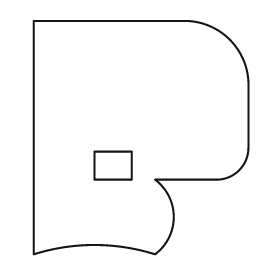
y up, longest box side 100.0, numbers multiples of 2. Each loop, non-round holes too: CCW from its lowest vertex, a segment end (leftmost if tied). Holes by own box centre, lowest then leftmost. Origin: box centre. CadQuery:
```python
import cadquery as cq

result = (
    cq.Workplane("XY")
    .moveTo(-46.0, -50.0)
    .threePointArc((-20.0, -46.0), (6.0, -50.0))
    .threePointArc((14.0, -34.0), (6.0, -18.0))
    .lineTo(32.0, -18.0)
    .threePointArc((42.0, -14.0), (46.0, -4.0))
    .lineTo(46.0, 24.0)
    .threePointArc((38.0, 42.0), (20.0, 50.0))
    .lineTo(-46.0, 50.0)
    .close()
    .moveTo(-20.0, -18.0)
    .lineTo(-4.0, -18.0)
    .lineTo(-4.0, -6.0)
    .lineTo(-20.0, -6.0)
    .close()
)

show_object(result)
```